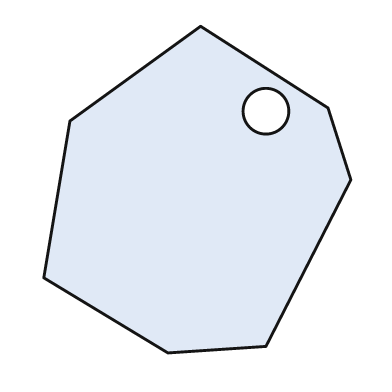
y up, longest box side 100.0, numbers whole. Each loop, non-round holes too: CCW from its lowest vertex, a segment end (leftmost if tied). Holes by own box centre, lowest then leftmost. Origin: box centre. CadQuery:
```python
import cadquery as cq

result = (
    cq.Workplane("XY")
    .moveTo(-9.0, -50.0)
    .lineTo(21.0, -48.0)
    .lineTo(47.0, 3.0)
    .lineTo(40.0, 25.0)
    .lineTo(1.0, 50.0)
    .lineTo(-39.0, 21.0)
    .lineTo(-47.0, -27.0)
    .close()
    .moveTo(21.0, 24.0)
    .circle(7.0)
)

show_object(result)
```